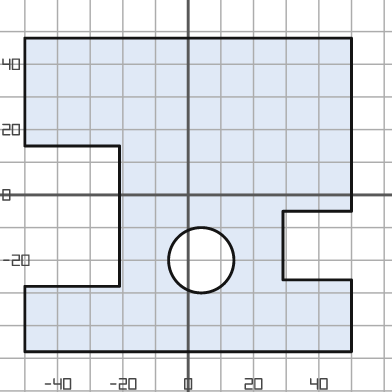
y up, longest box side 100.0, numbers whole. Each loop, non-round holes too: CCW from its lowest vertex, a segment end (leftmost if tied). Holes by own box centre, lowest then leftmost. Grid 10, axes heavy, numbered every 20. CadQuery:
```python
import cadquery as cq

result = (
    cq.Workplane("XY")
    .moveTo(-50.0, -48.0)
    .lineTo(50.0, -48.0)
    .lineTo(50.0, -26.0)
    .lineTo(29.0, -26.0)
    .lineTo(29.0, -5.0)
    .lineTo(50.0, -5.0)
    .lineTo(50.0, 48.0)
    .lineTo(-50.0, 48.0)
    .lineTo(-50.0, 15.0)
    .lineTo(-21.0, 15.0)
    .lineTo(-21.0, -28.0)
    .lineTo(-50.0, -28.0)
    .close()
    .moveTo(4.0, -20.0)
    .circle(10.0)
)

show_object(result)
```